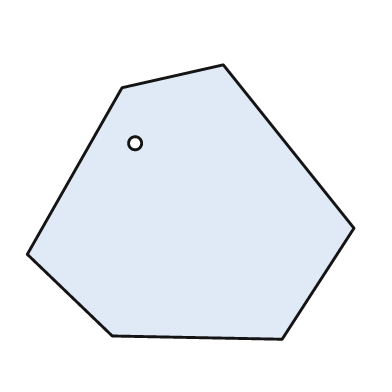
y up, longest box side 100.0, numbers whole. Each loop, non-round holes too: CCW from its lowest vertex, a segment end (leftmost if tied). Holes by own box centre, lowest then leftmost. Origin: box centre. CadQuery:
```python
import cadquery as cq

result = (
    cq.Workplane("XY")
    .moveTo(28.0, -42.0)
    .lineTo(50.0, -8.0)
    .lineTo(10.0, 42.0)
    .lineTo(-21.0, 35.0)
    .lineTo(-50.0, -16.0)
    .lineTo(-24.0, -41.0)
    .close()
    .moveTo(-17.0, 18.0)
    .circle(2.0)
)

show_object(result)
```